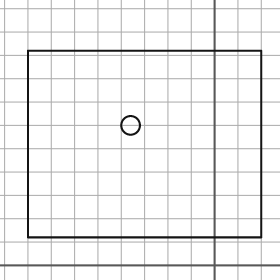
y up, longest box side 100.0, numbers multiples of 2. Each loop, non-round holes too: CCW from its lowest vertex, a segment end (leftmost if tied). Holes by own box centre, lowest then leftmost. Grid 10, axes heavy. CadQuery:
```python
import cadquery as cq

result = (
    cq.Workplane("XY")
    .moveTo(-80.0, 12.0)
    .lineTo(20.0, 12.0)
    .lineTo(20.0, 92.0)
    .lineTo(-80.0, 92.0)
    .close()
    .moveTo(-36.0, 60.0)
    .circle(4.0)
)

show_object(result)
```